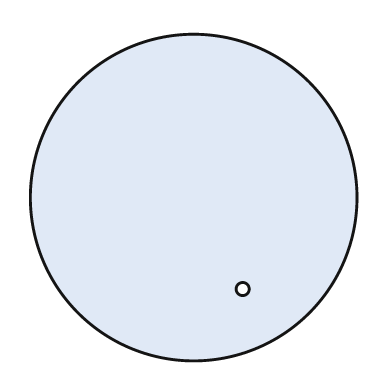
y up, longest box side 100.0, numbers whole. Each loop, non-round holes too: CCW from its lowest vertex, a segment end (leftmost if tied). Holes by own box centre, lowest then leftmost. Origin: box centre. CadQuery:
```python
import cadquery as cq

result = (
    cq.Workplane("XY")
    .moveTo(0.0, 0.0)
    .circle(50.0)
    .moveTo(15.0, -28.0)
    .circle(2.0)
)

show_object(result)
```